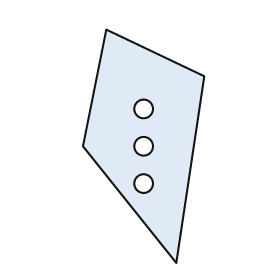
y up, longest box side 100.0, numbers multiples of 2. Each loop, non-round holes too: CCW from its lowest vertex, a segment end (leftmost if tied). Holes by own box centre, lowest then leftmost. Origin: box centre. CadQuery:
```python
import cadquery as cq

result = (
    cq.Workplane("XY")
    .moveTo(14.0, -50.0)
    .lineTo(26.0, 30.0)
    .lineTo(-16.0, 50.0)
    .lineTo(-26.0, 0.0)
    .close()
    .moveTo(0.0, -16.0)
    .circle(4.0)
    .moveTo(0.0, 0.0)
    .circle(4.0)
    .moveTo(0.0, 16.0)
    .circle(4.0)
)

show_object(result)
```